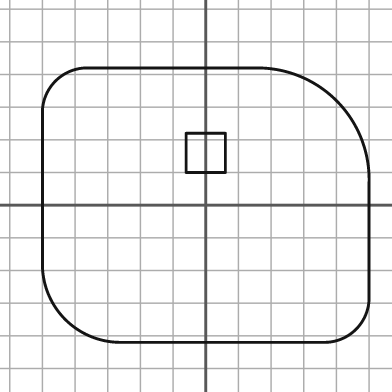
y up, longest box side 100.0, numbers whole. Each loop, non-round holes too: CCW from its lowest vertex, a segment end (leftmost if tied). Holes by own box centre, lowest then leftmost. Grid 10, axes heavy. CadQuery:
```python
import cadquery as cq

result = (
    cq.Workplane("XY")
    .moveTo(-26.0, -42.0)
    .lineTo(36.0, -42.0)
    .threePointArc((46.0, -38.0), (50.0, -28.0))
    .lineTo(50.0, 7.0)
    .threePointArc((40.0, 32.0), (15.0, 42.0))
    .lineTo(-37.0, 42.0)
    .threePointArc((-46.0, 38.0), (-50.0, 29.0))
    .lineTo(-50.0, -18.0)
    .threePointArc((-43.0, -35.0), (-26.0, -42.0))
    .close()
    .moveTo(-6.0, 10.0)
    .lineTo(6.0, 10.0)
    .lineTo(6.0, 22.0)
    .lineTo(-6.0, 22.0)
    .close()
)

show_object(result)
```